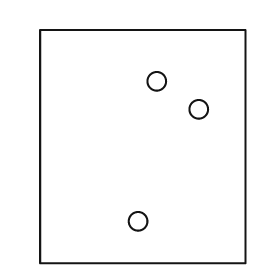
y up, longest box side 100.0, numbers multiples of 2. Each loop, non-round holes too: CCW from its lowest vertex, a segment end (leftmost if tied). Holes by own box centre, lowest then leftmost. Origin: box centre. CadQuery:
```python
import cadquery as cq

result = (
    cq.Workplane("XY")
    .moveTo(-44.0, -50.0)
    .lineTo(44.0, -50.0)
    .lineTo(44.0, 50.0)
    .lineTo(-44.0, 50.0)
    .close()
    .moveTo(-2.0, -32.0)
    .circle(4.0)
    .moveTo(24.0, 16.0)
    .circle(4.0)
    .moveTo(6.0, 28.0)
    .circle(4.0)
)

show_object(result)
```